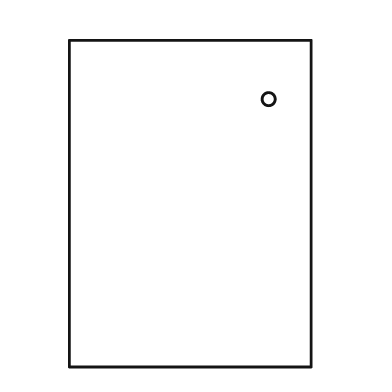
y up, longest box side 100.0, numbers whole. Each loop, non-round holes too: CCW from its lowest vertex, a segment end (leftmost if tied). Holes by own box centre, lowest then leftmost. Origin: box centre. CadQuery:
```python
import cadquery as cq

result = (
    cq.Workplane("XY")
    .moveTo(-37.0, -50.0)
    .lineTo(37.0, -50.0)
    .lineTo(37.0, 50.0)
    .lineTo(-37.0, 50.0)
    .close()
    .moveTo(24.0, 32.0)
    .circle(2.0)
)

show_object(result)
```